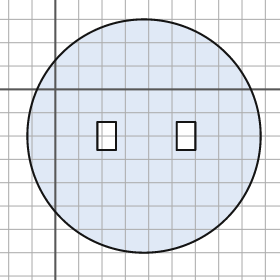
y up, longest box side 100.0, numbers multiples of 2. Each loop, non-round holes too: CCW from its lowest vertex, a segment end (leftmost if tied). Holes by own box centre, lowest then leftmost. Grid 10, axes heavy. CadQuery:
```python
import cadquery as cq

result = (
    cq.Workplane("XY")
    .moveTo(38.0, -20.0)
    .circle(50.0)
    .moveTo(18.0, -26.0)
    .lineTo(26.0, -26.0)
    .lineTo(26.0, -14.0)
    .lineTo(18.0, -14.0)
    .close()
    .moveTo(52.0, -26.0)
    .lineTo(60.0, -26.0)
    .lineTo(60.0, -14.0)
    .lineTo(52.0, -14.0)
    .close()
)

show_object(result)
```